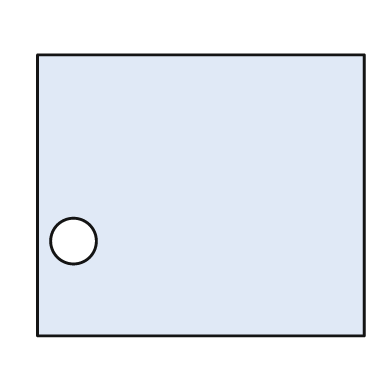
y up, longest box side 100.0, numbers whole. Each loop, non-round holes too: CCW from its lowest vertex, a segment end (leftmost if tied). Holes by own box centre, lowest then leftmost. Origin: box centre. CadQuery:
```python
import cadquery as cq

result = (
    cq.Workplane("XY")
    .moveTo(-50.0, -43.0)
    .lineTo(50.0, -43.0)
    .lineTo(50.0, 43.0)
    .lineTo(-50.0, 43.0)
    .close()
    .moveTo(-39.0, -14.0)
    .circle(7.0)
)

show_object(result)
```